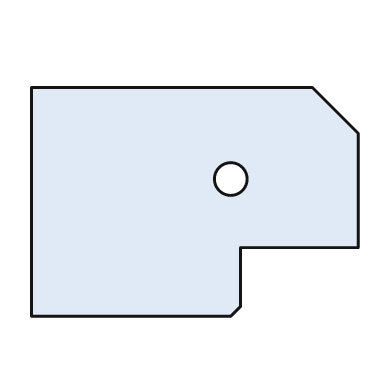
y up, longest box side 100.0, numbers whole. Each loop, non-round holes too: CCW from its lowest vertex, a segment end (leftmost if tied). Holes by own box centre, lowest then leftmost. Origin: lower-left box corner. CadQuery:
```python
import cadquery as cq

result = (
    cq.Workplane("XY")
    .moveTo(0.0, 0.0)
    .lineTo(61.0, 0.0)
    .lineTo(64.0, 3.0)
    .lineTo(64.0, 21.0)
    .lineTo(100.0, 21.0)
    .lineTo(100.0, 56.0)
    .lineTo(86.0, 70.0)
    .lineTo(0.0, 70.0)
    .close()
    .moveTo(61.0, 42.0)
    .circle(5.0)
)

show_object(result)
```